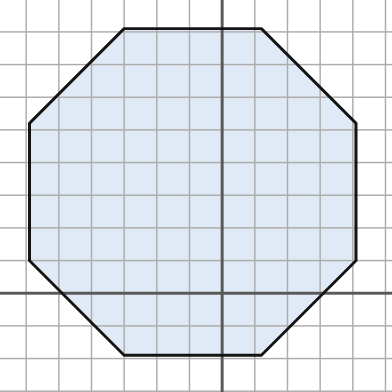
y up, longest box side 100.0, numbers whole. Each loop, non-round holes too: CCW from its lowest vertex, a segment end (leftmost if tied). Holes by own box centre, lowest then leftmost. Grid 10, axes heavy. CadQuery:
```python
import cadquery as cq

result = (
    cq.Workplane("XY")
    .moveTo(-30.0, -19.0)
    .lineTo(12.0, -19.0)
    .lineTo(41.0, 10.0)
    .lineTo(41.0, 52.0)
    .lineTo(12.0, 81.0)
    .lineTo(-30.0, 81.0)
    .lineTo(-59.0, 52.0)
    .lineTo(-59.0, 10.0)
    .close()
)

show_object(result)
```